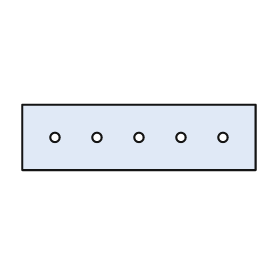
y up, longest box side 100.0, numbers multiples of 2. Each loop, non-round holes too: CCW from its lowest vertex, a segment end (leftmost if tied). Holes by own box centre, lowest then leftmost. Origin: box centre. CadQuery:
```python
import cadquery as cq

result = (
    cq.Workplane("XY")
    .moveTo(-50.0, -14.0)
    .lineTo(50.0, -14.0)
    .lineTo(50.0, 14.0)
    .lineTo(-50.0, 14.0)
    .close()
    .moveTo(-36.0, 0.0)
    .circle(2.0)
    .moveTo(-18.0, 0.0)
    .circle(2.0)
    .moveTo(0.0, 0.0)
    .circle(2.0)
    .moveTo(18.0, 0.0)
    .circle(2.0)
    .moveTo(36.0, 0.0)
    .circle(2.0)
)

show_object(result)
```